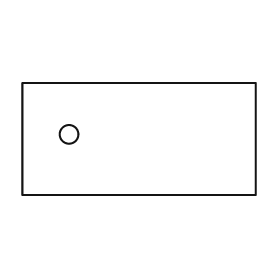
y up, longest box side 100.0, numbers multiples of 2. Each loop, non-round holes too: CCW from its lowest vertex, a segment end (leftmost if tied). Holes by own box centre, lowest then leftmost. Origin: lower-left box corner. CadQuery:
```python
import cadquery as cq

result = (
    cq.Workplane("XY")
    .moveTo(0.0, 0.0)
    .lineTo(100.0, 0.0)
    .lineTo(100.0, 48.0)
    .lineTo(0.0, 48.0)
    .close()
    .moveTo(20.0, 26.0)
    .circle(4.0)
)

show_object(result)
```